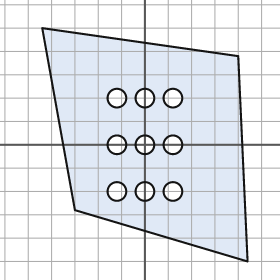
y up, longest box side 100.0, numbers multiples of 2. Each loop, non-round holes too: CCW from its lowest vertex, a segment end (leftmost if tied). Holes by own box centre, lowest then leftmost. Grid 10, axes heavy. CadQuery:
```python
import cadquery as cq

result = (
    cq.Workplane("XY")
    .moveTo(44.0, -50.0)
    .lineTo(40.0, 38.0)
    .lineTo(-44.0, 50.0)
    .lineTo(-30.0, -28.0)
    .close()
    .moveTo(-12.0, -20.0)
    .circle(4.0)
    .moveTo(0.0, -20.0)
    .circle(4.0)
    .moveTo(12.0, -20.0)
    .circle(4.0)
    .moveTo(-12.0, 0.0)
    .circle(4.0)
    .moveTo(0.0, 0.0)
    .circle(4.0)
    .moveTo(12.0, 0.0)
    .circle(4.0)
    .moveTo(-12.0, 20.0)
    .circle(4.0)
    .moveTo(0.0, 20.0)
    .circle(4.0)
    .moveTo(12.0, 20.0)
    .circle(4.0)
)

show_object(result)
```